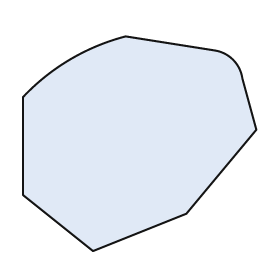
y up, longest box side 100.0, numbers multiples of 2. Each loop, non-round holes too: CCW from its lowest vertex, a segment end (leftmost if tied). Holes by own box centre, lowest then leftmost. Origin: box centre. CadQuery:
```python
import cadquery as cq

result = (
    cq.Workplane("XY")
    .moveTo(-20.0, -46.0)
    .lineTo(20.0, -30.0)
    .lineTo(50.0, 6.0)
    .lineTo(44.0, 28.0)
    .threePointArc((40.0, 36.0), (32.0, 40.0))
    .lineTo(-6.0, 46.0)
    .threePointArc((-30.0, 36.0), (-50.0, 20.0))
    .lineTo(-50.0, -22.0)
    .close()
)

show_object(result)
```